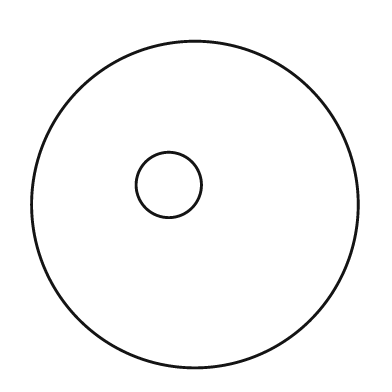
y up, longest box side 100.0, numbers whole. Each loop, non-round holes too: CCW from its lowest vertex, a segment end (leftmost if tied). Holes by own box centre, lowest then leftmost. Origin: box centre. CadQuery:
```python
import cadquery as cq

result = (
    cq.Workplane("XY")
    .moveTo(0.0, 0.0)
    .circle(50.0)
    .moveTo(-8.0, 6.0)
    .circle(10.0)
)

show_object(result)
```